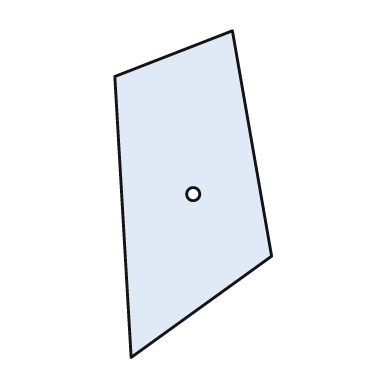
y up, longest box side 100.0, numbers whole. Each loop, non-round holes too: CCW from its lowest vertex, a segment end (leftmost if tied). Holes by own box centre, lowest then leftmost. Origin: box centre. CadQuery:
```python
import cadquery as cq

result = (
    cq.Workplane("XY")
    .moveTo(-19.0, -50.0)
    .lineTo(24.0, -19.0)
    .lineTo(12.0, 50.0)
    .lineTo(-24.0, 36.0)
    .close()
    .moveTo(0.0, 0.0)
    .circle(2.0)
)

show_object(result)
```